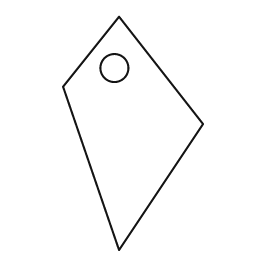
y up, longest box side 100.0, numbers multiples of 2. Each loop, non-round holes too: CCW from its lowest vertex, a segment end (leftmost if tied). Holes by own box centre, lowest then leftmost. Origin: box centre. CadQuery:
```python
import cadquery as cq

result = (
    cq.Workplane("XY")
    .moveTo(-6.0, -50.0)
    .lineTo(30.0, 4.0)
    .lineTo(-6.0, 50.0)
    .lineTo(-30.0, 20.0)
    .close()
    .moveTo(-8.0, 28.0)
    .circle(6.0)
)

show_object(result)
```